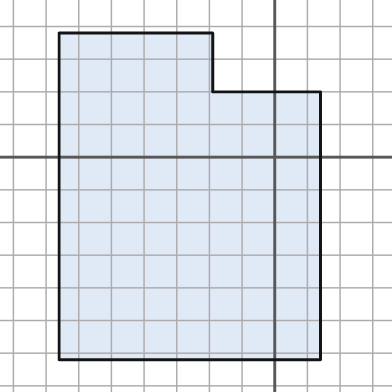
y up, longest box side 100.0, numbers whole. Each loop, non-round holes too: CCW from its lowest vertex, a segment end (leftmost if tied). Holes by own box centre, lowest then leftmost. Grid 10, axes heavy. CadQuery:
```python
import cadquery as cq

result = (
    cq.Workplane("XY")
    .moveTo(-66.0, -62.0)
    .lineTo(14.0, -62.0)
    .lineTo(14.0, 20.0)
    .lineTo(-19.0, 20.0)
    .lineTo(-19.0, 38.0)
    .lineTo(-66.0, 38.0)
    .close()
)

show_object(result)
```